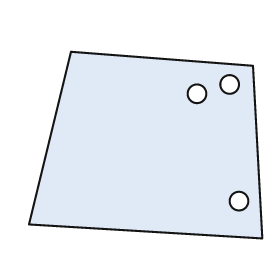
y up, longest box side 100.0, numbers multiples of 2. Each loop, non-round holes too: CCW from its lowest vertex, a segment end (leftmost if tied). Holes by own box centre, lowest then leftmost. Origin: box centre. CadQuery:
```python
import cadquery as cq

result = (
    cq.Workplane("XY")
    .moveTo(50.0, -40.0)
    .lineTo(46.0, 34.0)
    .lineTo(-32.0, 40.0)
    .lineTo(-50.0, -34.0)
    .close()
    .moveTo(40.0, -24.0)
    .circle(4.0)
    .moveTo(22.0, 22.0)
    .circle(4.0)
    .moveTo(36.0, 26.0)
    .circle(4.0)
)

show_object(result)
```